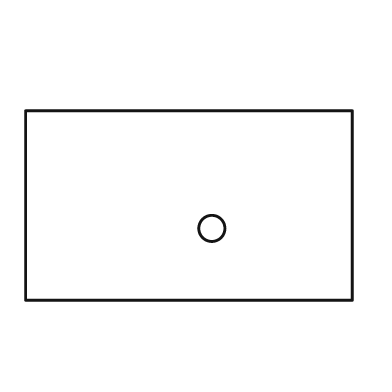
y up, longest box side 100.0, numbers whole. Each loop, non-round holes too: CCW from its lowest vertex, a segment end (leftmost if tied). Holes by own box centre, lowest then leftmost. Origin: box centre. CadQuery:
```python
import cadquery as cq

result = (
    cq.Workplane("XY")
    .moveTo(-50.0, -29.0)
    .lineTo(50.0, -29.0)
    .lineTo(50.0, 29.0)
    .lineTo(-50.0, 29.0)
    .close()
    .moveTo(7.0, -7.0)
    .circle(4.0)
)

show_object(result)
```